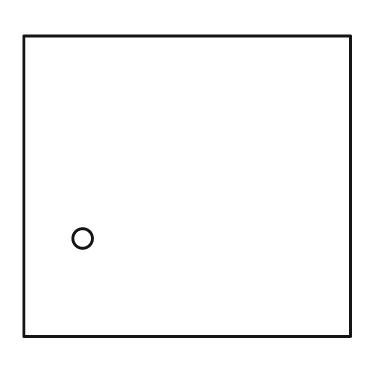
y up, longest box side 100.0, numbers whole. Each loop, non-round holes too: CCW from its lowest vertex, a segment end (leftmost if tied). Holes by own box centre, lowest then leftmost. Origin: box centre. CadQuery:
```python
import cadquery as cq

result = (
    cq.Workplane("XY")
    .moveTo(-50.0, -46.0)
    .lineTo(50.0, -46.0)
    .lineTo(50.0, 46.0)
    .lineTo(-50.0, 46.0)
    .close()
    .moveTo(-32.0, -16.0)
    .circle(3.0)
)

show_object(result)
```